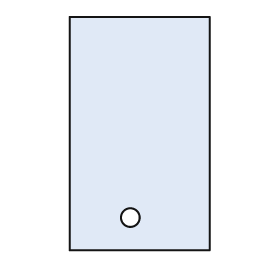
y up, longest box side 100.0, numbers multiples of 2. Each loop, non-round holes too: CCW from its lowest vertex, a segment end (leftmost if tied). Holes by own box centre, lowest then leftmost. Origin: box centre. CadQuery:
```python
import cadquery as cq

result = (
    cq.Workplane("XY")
    .moveTo(-30.0, -50.0)
    .lineTo(30.0, -50.0)
    .lineTo(30.0, 50.0)
    .lineTo(-30.0, 50.0)
    .close()
    .moveTo(-4.0, -36.0)
    .circle(4.0)
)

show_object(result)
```